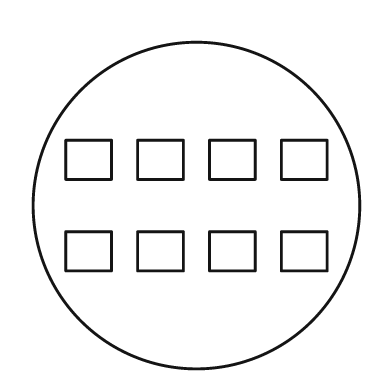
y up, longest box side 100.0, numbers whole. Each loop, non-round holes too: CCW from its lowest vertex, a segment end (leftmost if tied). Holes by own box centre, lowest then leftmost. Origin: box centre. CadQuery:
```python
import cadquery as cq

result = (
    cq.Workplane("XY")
    .moveTo(0.0, 0.0)
    .circle(50.0)
    .moveTo(-40.0, -20.0)
    .lineTo(-26.0, -20.0)
    .lineTo(-26.0, -8.0)
    .lineTo(-40.0, -8.0)
    .close()
    .moveTo(-18.0, -20.0)
    .lineTo(-4.0, -20.0)
    .lineTo(-4.0, -8.0)
    .lineTo(-18.0, -8.0)
    .close()
    .moveTo(4.0, -20.0)
    .lineTo(18.0, -20.0)
    .lineTo(18.0, -8.0)
    .lineTo(4.0, -8.0)
    .close()
    .moveTo(26.0, -20.0)
    .lineTo(40.0, -20.0)
    .lineTo(40.0, -8.0)
    .lineTo(26.0, -8.0)
    .close()
    .moveTo(-40.0, 8.0)
    .lineTo(-26.0, 8.0)
    .lineTo(-26.0, 20.0)
    .lineTo(-40.0, 20.0)
    .close()
    .moveTo(-18.0, 8.0)
    .lineTo(-4.0, 8.0)
    .lineTo(-4.0, 20.0)
    .lineTo(-18.0, 20.0)
    .close()
    .moveTo(4.0, 8.0)
    .lineTo(18.0, 8.0)
    .lineTo(18.0, 20.0)
    .lineTo(4.0, 20.0)
    .close()
    .moveTo(26.0, 8.0)
    .lineTo(40.0, 8.0)
    .lineTo(40.0, 20.0)
    .lineTo(26.0, 20.0)
    .close()
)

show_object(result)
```